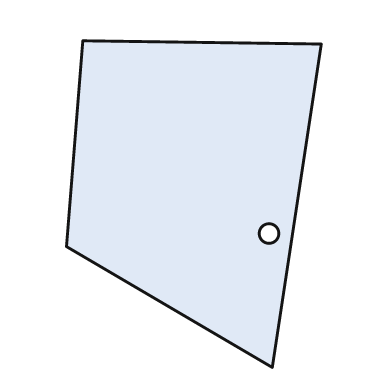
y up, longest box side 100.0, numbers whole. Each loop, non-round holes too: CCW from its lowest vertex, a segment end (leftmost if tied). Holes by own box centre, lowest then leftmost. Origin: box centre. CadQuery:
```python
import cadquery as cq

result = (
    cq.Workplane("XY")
    .moveTo(24.0, -50.0)
    .lineTo(39.0, 49.0)
    .lineTo(-34.0, 50.0)
    .lineTo(-39.0, -13.0)
    .close()
    .moveTo(23.0, -9.0)
    .circle(3.0)
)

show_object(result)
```